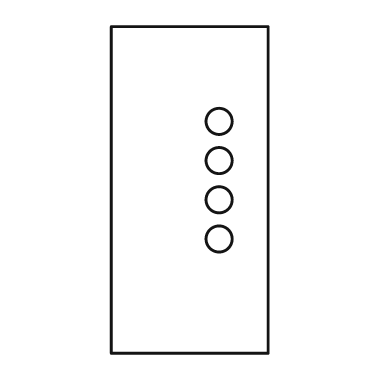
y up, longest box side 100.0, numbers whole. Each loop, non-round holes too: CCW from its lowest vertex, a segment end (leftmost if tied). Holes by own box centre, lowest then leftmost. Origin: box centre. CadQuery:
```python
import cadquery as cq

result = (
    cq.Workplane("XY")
    .moveTo(-24.0, -50.0)
    .lineTo(24.0, -50.0)
    .lineTo(24.0, 50.0)
    .lineTo(-24.0, 50.0)
    .close()
    .moveTo(9.0, -15.0)
    .circle(4.0)
    .moveTo(9.0, -3.0)
    .circle(4.0)
    .moveTo(9.0, 9.0)
    .circle(4.0)
    .moveTo(9.0, 21.0)
    .circle(4.0)
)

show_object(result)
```